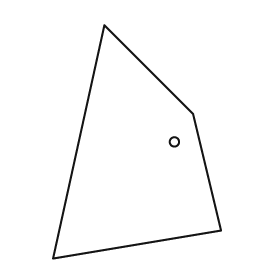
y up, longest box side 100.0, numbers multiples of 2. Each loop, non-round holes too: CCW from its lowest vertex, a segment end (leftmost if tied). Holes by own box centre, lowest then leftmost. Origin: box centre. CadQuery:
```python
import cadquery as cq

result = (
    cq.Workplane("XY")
    .moveTo(-36.0, -50.0)
    .lineTo(36.0, -38.0)
    .lineTo(24.0, 12.0)
    .lineTo(-14.0, 50.0)
    .close()
    .moveTo(16.0, 0.0)
    .circle(2.0)
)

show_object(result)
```